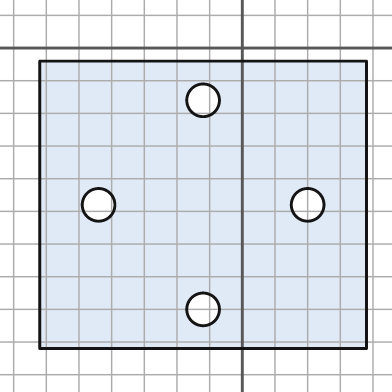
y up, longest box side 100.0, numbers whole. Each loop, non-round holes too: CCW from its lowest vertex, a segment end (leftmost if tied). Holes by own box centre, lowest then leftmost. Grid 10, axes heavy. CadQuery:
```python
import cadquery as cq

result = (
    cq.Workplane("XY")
    .moveTo(-62.0, -92.0)
    .lineTo(38.0, -92.0)
    .lineTo(38.0, -4.0)
    .lineTo(-62.0, -4.0)
    .close()
    .moveTo(-12.0, -80.0)
    .circle(5.0)
    .moveTo(-44.0, -48.0)
    .circle(5.0)
    .moveTo(20.0, -48.0)
    .circle(5.0)
    .moveTo(-12.0, -16.0)
    .circle(5.0)
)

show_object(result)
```